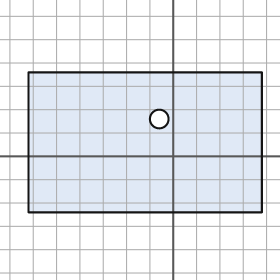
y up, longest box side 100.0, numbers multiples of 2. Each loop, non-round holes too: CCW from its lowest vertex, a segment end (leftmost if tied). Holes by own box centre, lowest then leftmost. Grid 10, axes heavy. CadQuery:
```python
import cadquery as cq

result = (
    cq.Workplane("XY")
    .moveTo(-62.0, -24.0)
    .lineTo(38.0, -24.0)
    .lineTo(38.0, 36.0)
    .lineTo(-62.0, 36.0)
    .close()
    .moveTo(-6.0, 16.0)
    .circle(4.0)
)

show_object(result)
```